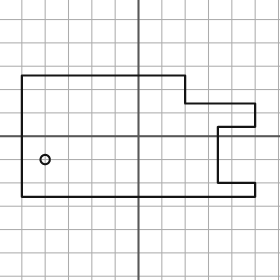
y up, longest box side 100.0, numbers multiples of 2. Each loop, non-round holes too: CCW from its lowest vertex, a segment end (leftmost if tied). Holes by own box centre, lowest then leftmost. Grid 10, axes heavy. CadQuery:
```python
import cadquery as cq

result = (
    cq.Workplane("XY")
    .moveTo(-50.0, -26.0)
    .lineTo(50.0, -26.0)
    .lineTo(50.0, -20.0)
    .lineTo(34.0, -20.0)
    .lineTo(34.0, 4.0)
    .lineTo(50.0, 4.0)
    .lineTo(50.0, 14.0)
    .lineTo(20.0, 14.0)
    .lineTo(20.0, 26.0)
    .lineTo(-50.0, 26.0)
    .close()
    .moveTo(-40.0, -10.0)
    .circle(2.0)
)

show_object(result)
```